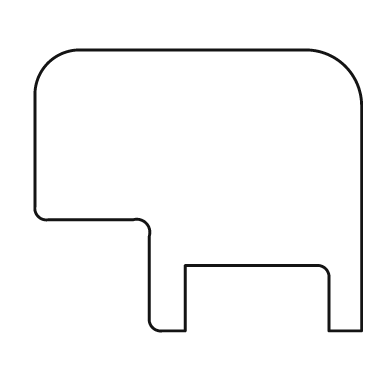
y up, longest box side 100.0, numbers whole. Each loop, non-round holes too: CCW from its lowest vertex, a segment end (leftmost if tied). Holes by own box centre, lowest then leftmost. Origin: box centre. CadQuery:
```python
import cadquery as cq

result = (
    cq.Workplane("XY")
    .moveTo(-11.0, -43.0)
    .lineTo(-4.0, -43.0)
    .lineTo(-4.0, -23.0)
    .lineTo(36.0, -23.0)
    .threePointArc((39.0, -24.0), (40.0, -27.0))
    .lineTo(40.0, -43.0)
    .lineTo(50.0, -43.0)
    .lineTo(50.0, 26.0)
    .threePointArc((45.0, 38.0), (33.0, 43.0))
    .lineTo(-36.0, 43.0)
    .threePointArc((-46.0, 39.0), (-50.0, 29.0))
    .lineTo(-50.0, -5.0)
    .threePointArc((-49.0, -8.0), (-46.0, -9.0))
    .lineTo(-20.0, -9.0)
    .threePointArc((-16.0, -10.0), (-15.0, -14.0))
    .lineTo(-15.0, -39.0)
    .threePointArc((-14.0, -42.0), (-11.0, -43.0))
    .close()
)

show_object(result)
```